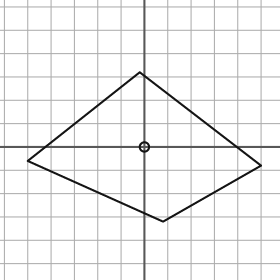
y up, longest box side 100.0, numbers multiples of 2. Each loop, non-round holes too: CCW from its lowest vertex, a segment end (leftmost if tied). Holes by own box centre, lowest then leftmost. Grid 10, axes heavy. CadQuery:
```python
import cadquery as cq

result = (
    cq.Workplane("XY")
    .moveTo(8.0, -32.0)
    .lineTo(50.0, -8.0)
    .lineTo(-2.0, 32.0)
    .lineTo(-50.0, -6.0)
    .close()
    .moveTo(0.0, 0.0)
    .circle(2.0)
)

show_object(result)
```